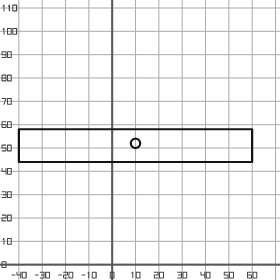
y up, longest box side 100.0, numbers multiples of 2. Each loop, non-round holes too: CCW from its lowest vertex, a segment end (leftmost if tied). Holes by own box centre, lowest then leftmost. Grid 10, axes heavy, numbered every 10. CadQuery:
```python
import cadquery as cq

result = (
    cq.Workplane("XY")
    .moveTo(-40.0, 44.0)
    .lineTo(60.0, 44.0)
    .lineTo(60.0, 58.0)
    .lineTo(-40.0, 58.0)
    .close()
    .moveTo(10.0, 52.0)
    .circle(2.0)
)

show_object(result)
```